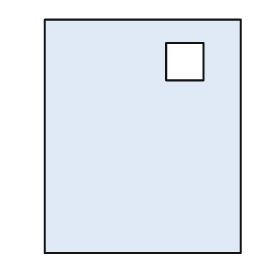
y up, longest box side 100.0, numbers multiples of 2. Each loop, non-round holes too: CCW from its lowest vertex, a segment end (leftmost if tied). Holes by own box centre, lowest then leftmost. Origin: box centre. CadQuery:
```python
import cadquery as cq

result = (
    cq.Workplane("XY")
    .moveTo(-42.0, -50.0)
    .lineTo(42.0, -50.0)
    .lineTo(42.0, 50.0)
    .lineTo(-42.0, 50.0)
    .close()
    .moveTo(10.0, 24.0)
    .lineTo(26.0, 24.0)
    .lineTo(26.0, 40.0)
    .lineTo(10.0, 40.0)
    .close()
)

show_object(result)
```